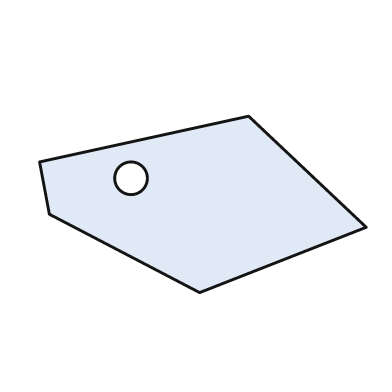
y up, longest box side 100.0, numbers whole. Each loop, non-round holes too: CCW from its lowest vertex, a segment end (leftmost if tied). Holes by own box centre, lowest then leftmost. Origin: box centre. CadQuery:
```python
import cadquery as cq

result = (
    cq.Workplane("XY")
    .moveTo(-1.0, -27.0)
    .lineTo(50.0, -7.0)
    .lineTo(14.0, 27.0)
    .lineTo(-50.0, 13.0)
    .lineTo(-47.0, -3.0)
    .close()
    .moveTo(-22.0, 8.0)
    .circle(5.0)
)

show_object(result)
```